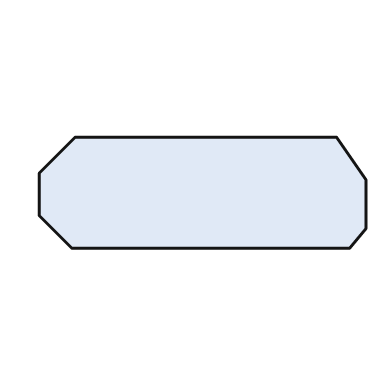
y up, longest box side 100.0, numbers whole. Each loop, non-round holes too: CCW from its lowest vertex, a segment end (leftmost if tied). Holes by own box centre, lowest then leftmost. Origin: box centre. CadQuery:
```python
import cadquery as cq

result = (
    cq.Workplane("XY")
    .moveTo(-40.0, -17.0)
    .lineTo(45.0, -17.0)
    .lineTo(50.0, -11.0)
    .lineTo(50.0, 4.0)
    .lineTo(41.0, 17.0)
    .lineTo(-39.0, 17.0)
    .lineTo(-50.0, 6.0)
    .lineTo(-50.0, -7.0)
    .close()
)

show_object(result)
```